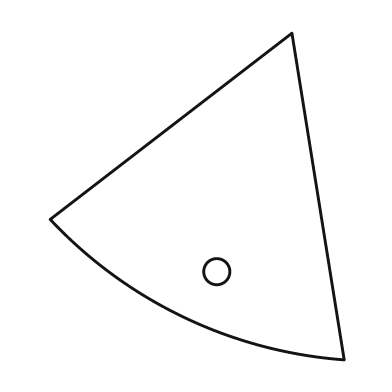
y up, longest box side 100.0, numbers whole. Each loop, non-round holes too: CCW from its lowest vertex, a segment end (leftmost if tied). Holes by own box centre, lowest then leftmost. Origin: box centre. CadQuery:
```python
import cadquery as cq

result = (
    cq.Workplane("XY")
    .moveTo(45.0, -50.0)
    .lineTo(29.0, 50.0)
    .lineTo(-45.0, -7.0)
    .threePointArc((-4.0, -37.0), (45.0, -50.0))
    .close()
    .moveTo(6.0, -23.0)
    .circle(4.0)
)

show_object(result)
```